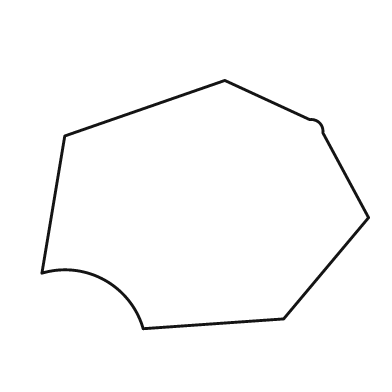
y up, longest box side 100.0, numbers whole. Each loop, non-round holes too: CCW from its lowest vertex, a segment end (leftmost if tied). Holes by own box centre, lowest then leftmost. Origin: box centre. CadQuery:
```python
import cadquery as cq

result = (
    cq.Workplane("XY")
    .moveTo(-19.0, -38.0)
    .lineTo(24.0, -35.0)
    .lineTo(50.0, -4.0)
    .lineTo(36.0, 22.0)
    .threePointArc((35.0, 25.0), (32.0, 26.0))
    .lineTo(6.0, 38.0)
    .lineTo(-43.0, 21.0)
    .lineTo(-50.0, -21.0)
    .threePointArc((-31.0, -23.0), (-19.0, -38.0))
    .close()
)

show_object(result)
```